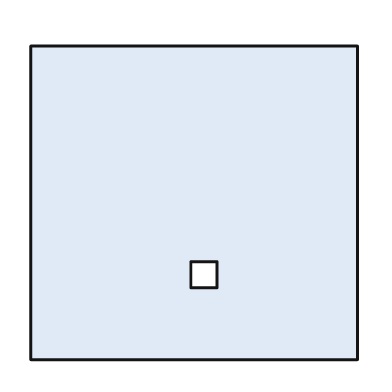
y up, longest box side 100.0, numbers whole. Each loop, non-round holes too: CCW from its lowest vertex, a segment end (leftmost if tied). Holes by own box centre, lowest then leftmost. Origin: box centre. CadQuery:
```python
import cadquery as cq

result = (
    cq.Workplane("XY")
    .moveTo(-50.0, -48.0)
    .lineTo(50.0, -48.0)
    .lineTo(50.0, 48.0)
    .lineTo(-50.0, 48.0)
    .close()
    .moveTo(-1.0, -26.0)
    .lineTo(7.0, -26.0)
    .lineTo(7.0, -18.0)
    .lineTo(-1.0, -18.0)
    .close()
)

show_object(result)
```